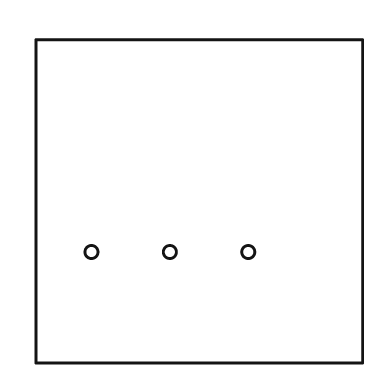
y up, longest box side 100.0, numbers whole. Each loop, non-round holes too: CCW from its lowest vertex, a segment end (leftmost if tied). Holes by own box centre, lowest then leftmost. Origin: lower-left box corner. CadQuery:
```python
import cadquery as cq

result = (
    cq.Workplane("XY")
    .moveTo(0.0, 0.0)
    .lineTo(100.0, 0.0)
    .lineTo(100.0, 99.0)
    .lineTo(0.0, 99.0)
    .close()
    .moveTo(17.0, 34.0)
    .circle(2.0)
    .moveTo(41.0, 34.0)
    .circle(2.0)
    .moveTo(65.0, 34.0)
    .circle(2.0)
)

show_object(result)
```